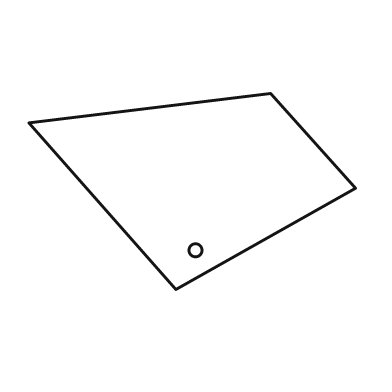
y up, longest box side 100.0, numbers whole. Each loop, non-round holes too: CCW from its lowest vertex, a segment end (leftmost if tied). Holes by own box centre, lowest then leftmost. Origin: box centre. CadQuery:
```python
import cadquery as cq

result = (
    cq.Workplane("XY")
    .moveTo(-5.0, -30.0)
    .lineTo(50.0, 1.0)
    .lineTo(24.0, 30.0)
    .lineTo(-50.0, 21.0)
    .close()
    .moveTo(1.0, -18.0)
    .circle(2.0)
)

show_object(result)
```